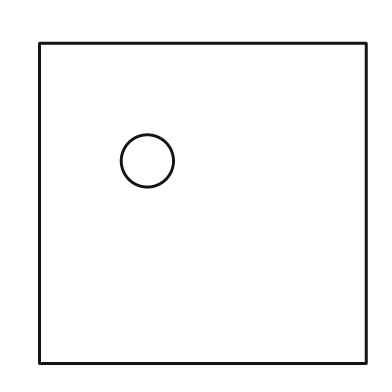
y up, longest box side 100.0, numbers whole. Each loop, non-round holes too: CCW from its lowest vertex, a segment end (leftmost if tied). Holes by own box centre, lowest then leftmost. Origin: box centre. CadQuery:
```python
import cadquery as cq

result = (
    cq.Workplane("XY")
    .moveTo(-50.0, -49.0)
    .lineTo(50.0, -49.0)
    .lineTo(50.0, 49.0)
    .lineTo(-50.0, 49.0)
    .close()
    .moveTo(-17.0, 13.0)
    .circle(8.0)
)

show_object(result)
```